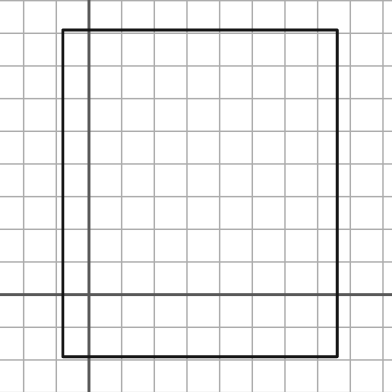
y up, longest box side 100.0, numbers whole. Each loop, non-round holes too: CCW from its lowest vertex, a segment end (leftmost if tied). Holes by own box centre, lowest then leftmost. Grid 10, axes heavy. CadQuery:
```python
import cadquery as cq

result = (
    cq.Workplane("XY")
    .moveTo(-8.0, -19.0)
    .lineTo(76.0, -19.0)
    .lineTo(76.0, 81.0)
    .lineTo(-8.0, 81.0)
    .close()
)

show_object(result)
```